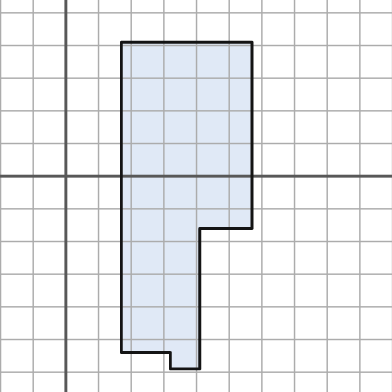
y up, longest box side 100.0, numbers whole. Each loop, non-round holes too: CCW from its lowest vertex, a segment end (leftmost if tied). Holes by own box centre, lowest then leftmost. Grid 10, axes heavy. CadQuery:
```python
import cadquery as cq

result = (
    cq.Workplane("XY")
    .moveTo(32.0, -59.0)
    .lineTo(41.0, -59.0)
    .lineTo(41.0, -16.0)
    .lineTo(57.0, -16.0)
    .lineTo(57.0, 41.0)
    .lineTo(17.0, 41.0)
    .lineTo(17.0, -54.0)
    .lineTo(32.0, -54.0)
    .close()
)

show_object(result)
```